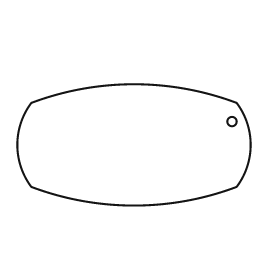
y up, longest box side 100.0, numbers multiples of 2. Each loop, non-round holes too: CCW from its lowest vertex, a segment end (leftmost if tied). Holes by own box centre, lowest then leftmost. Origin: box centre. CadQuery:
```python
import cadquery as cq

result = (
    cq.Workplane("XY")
    .moveTo(-44.0, -18.0)
    .threePointArc((0.0, -26.0), (44.0, -18.0))
    .threePointArc((50.0, 0.0), (44.0, 18.0))
    .threePointArc((0.0, 26.0), (-44.0, 18.0))
    .threePointArc((-50.0, 0.0), (-44.0, -18.0))
    .close()
    .moveTo(42.0, 10.0)
    .circle(2.0)
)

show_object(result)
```